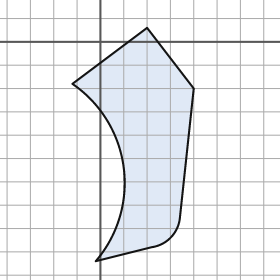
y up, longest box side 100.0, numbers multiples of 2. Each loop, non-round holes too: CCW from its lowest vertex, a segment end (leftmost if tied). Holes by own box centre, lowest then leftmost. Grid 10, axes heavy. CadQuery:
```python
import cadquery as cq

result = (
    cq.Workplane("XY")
    .moveTo(-2.0, -94.0)
    .lineTo(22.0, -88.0)
    .threePointArc((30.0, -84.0), (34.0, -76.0))
    .lineTo(40.0, -20.0)
    .lineTo(20.0, 6.0)
    .lineTo(-12.0, -18.0)
    .threePointArc((10.0, -54.0), (-2.0, -94.0))
    .close()
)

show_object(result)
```